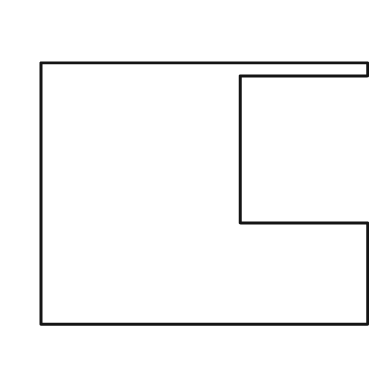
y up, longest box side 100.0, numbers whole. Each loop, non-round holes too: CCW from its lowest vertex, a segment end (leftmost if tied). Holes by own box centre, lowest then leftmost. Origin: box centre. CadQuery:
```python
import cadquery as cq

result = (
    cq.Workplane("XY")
    .moveTo(-50.0, -40.0)
    .lineTo(50.0, -40.0)
    .lineTo(50.0, -9.0)
    .lineTo(11.0, -9.0)
    .lineTo(11.0, 36.0)
    .lineTo(50.0, 36.0)
    .lineTo(50.0, 40.0)
    .lineTo(-50.0, 40.0)
    .close()
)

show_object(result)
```